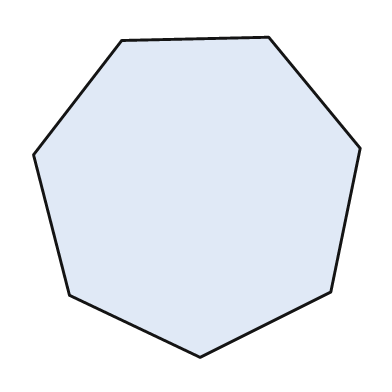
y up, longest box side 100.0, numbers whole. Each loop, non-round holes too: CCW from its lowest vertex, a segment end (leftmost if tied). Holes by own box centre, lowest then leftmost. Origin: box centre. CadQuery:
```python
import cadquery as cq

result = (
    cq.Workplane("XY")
    .moveTo(1.0, -49.0)
    .lineTo(41.0, -29.0)
    .lineTo(50.0, 15.0)
    .lineTo(22.0, 49.0)
    .lineTo(-23.0, 48.0)
    .lineTo(-50.0, 13.0)
    .lineTo(-39.0, -30.0)
    .close()
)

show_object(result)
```